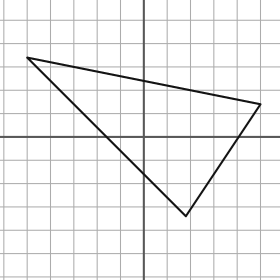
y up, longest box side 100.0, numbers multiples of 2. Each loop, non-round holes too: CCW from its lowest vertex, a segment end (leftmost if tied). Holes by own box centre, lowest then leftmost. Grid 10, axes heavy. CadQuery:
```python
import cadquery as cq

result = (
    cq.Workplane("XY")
    .moveTo(18.0, -34.0)
    .lineTo(50.0, 14.0)
    .lineTo(-50.0, 34.0)
    .close()
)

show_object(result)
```